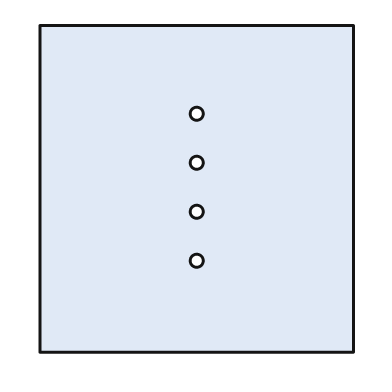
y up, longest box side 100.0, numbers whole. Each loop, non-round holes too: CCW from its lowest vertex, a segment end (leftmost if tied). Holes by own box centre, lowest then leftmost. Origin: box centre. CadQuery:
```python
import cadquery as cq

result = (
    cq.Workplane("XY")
    .moveTo(-48.0, -50.0)
    .lineTo(48.0, -50.0)
    .lineTo(48.0, 50.0)
    .lineTo(-48.0, 50.0)
    .close()
    .moveTo(0.0, -22.0)
    .circle(2.0)
    .moveTo(0.0, -7.0)
    .circle(2.0)
    .moveTo(0.0, 8.0)
    .circle(2.0)
    .moveTo(0.0, 23.0)
    .circle(2.0)
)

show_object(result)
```